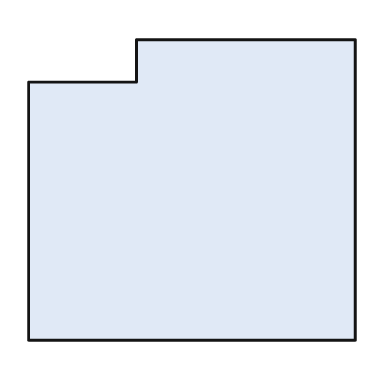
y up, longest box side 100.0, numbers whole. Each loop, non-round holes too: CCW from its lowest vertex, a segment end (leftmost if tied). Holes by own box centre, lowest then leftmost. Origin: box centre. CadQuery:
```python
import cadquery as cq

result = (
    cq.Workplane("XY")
    .moveTo(-50.0, -46.0)
    .lineTo(50.0, -46.0)
    .lineTo(50.0, 46.0)
    .lineTo(-17.0, 46.0)
    .lineTo(-17.0, 33.0)
    .lineTo(-50.0, 33.0)
    .close()
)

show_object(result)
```